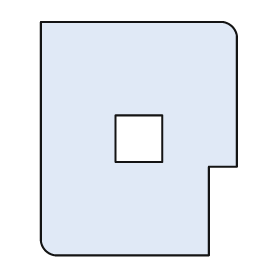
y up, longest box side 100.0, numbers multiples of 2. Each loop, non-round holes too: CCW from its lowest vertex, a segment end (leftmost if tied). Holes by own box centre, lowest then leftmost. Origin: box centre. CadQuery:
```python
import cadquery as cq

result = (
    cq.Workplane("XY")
    .moveTo(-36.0, -50.0)
    .lineTo(30.0, -50.0)
    .lineTo(30.0, -12.0)
    .lineTo(42.0, -12.0)
    .lineTo(42.0, 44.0)
    .threePointArc((40.0, 48.0), (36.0, 50.0))
    .lineTo(-42.0, 50.0)
    .lineTo(-42.0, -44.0)
    .threePointArc((-40.0, -48.0), (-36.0, -50.0))
    .close()
    .moveTo(-10.0, -10.0)
    .lineTo(10.0, -10.0)
    .lineTo(10.0, 10.0)
    .lineTo(-10.0, 10.0)
    .close()
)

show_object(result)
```